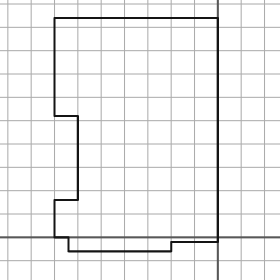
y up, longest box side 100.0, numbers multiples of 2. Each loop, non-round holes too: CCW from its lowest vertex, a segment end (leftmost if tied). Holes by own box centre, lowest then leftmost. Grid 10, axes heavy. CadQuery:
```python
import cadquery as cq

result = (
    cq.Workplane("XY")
    .moveTo(-64.0, -6.0)
    .lineTo(-20.0, -6.0)
    .lineTo(-20.0, -2.0)
    .lineTo(0.0, -2.0)
    .lineTo(0.0, 94.0)
    .lineTo(-70.0, 94.0)
    .lineTo(-70.0, 52.0)
    .lineTo(-60.0, 52.0)
    .lineTo(-60.0, 16.0)
    .lineTo(-70.0, 16.0)
    .lineTo(-70.0, 0.0)
    .lineTo(-64.0, 0.0)
    .close()
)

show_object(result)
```